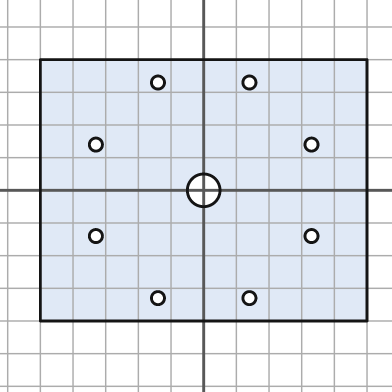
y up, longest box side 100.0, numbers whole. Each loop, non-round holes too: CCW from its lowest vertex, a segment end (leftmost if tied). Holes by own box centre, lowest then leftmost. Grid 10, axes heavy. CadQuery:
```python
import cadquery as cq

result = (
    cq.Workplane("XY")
    .moveTo(-50.0, -40.0)
    .lineTo(50.0, -40.0)
    .lineTo(50.0, 40.0)
    .lineTo(-50.0, 40.0)
    .close()
    .moveTo(-14.0, -33.0)
    .circle(2.0)
    .moveTo(14.0, -33.0)
    .circle(2.0)
    .moveTo(-33.0, -14.0)
    .circle(2.0)
    .moveTo(33.0, -14.0)
    .circle(2.0)
    .moveTo(0.0, 0.0)
    .circle(5.0)
    .moveTo(-33.0, 14.0)
    .circle(2.0)
    .moveTo(33.0, 14.0)
    .circle(2.0)
    .moveTo(-14.0, 33.0)
    .circle(2.0)
    .moveTo(14.0, 33.0)
    .circle(2.0)
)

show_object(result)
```